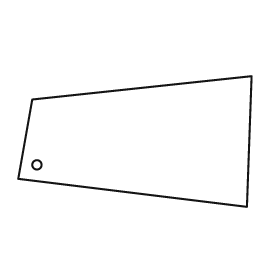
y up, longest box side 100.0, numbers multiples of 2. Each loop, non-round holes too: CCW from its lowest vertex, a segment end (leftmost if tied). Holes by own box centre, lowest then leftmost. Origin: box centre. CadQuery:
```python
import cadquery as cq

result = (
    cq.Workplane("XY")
    .moveTo(48.0, -28.0)
    .lineTo(50.0, 28.0)
    .lineTo(-44.0, 18.0)
    .lineTo(-50.0, -16.0)
    .close()
    .moveTo(-42.0, -10.0)
    .circle(2.0)
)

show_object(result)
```